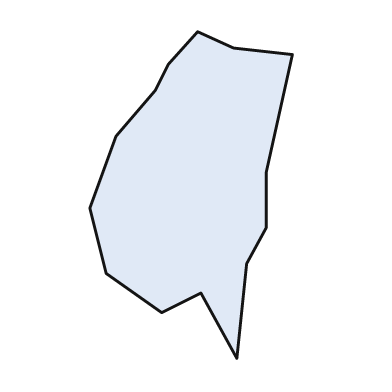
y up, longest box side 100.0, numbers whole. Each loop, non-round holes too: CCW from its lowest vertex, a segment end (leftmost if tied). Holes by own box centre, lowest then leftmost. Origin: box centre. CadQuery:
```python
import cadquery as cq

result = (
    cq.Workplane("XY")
    .moveTo(14.0, -50.0)
    .lineTo(17.0, -21.0)
    .lineTo(23.0, -10.0)
    .lineTo(23.0, 7.0)
    .lineTo(31.0, 43.0)
    .lineTo(13.0, 45.0)
    .lineTo(2.0, 50.0)
    .lineTo(-7.0, 40.0)
    .lineTo(-11.0, 32.0)
    .lineTo(-23.0, 18.0)
    .lineTo(-31.0, -4.0)
    .lineTo(-26.0, -24.0)
    .lineTo(-9.0, -36.0)
    .lineTo(3.0, -30.0)
    .close()
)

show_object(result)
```